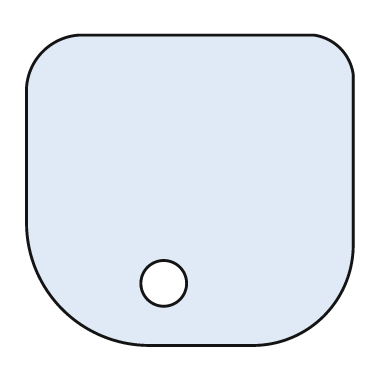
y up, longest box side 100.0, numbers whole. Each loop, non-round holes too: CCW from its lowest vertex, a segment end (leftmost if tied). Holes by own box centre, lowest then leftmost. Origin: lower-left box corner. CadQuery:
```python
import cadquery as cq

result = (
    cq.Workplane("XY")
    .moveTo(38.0, 0.0)
    .lineTo(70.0, 0.0)
    .threePointArc((91.0, 9.0), (100.0, 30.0))
    .lineTo(100.0, 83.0)
    .threePointArc((96.0, 91.0), (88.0, 95.0))
    .lineTo(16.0, 95.0)
    .threePointArc((5.0, 90.0), (0.0, 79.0))
    .lineTo(0.0, 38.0)
    .threePointArc((11.0, 11.0), (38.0, 0.0))
    .close()
    .moveTo(42.0, 19.0)
    .circle(7.0)
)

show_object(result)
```